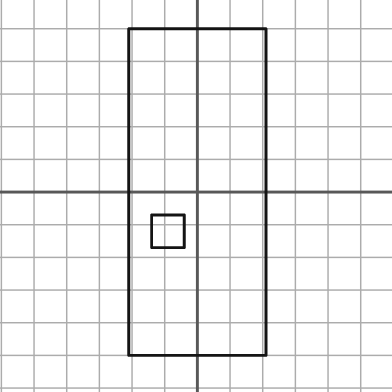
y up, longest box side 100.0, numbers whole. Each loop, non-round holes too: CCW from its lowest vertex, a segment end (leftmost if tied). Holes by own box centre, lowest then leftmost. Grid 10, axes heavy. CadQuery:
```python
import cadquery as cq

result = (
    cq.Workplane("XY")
    .moveTo(-21.0, -50.0)
    .lineTo(21.0, -50.0)
    .lineTo(21.0, 50.0)
    .lineTo(-21.0, 50.0)
    .close()
    .moveTo(-14.0, -17.0)
    .lineTo(-4.0, -17.0)
    .lineTo(-4.0, -7.0)
    .lineTo(-14.0, -7.0)
    .close()
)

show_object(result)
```